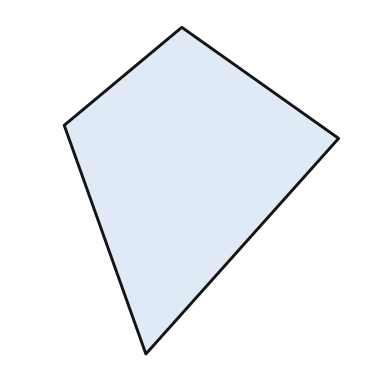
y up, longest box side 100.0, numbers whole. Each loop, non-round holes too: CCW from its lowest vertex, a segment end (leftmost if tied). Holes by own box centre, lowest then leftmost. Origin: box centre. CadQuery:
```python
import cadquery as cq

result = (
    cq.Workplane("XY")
    .moveTo(-17.0, -50.0)
    .lineTo(42.0, 16.0)
    .lineTo(-6.0, 50.0)
    .lineTo(-42.0, 20.0)
    .close()
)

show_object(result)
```